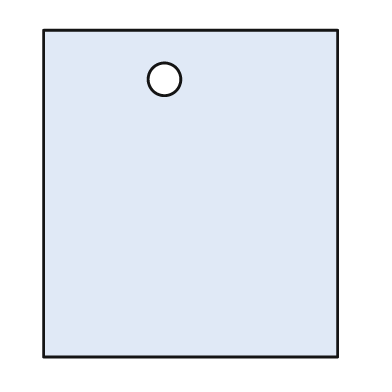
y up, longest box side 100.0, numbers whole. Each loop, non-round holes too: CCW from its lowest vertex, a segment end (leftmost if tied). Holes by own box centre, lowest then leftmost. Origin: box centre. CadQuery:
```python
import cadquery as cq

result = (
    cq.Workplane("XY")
    .moveTo(-45.0, -50.0)
    .lineTo(45.0, -50.0)
    .lineTo(45.0, 50.0)
    .lineTo(-45.0, 50.0)
    .close()
    .moveTo(-8.0, 35.0)
    .circle(5.0)
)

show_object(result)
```